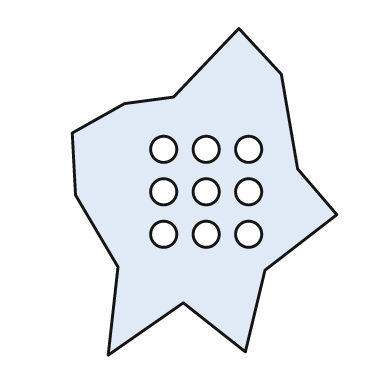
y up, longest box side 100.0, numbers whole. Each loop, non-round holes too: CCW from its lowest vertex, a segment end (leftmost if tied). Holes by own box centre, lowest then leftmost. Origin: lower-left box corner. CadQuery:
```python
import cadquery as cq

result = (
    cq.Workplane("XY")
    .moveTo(11.0, 0.0)
    .lineTo(34.0, 16.0)
    .lineTo(53.0, 1.0)
    .lineTo(59.0, 26.0)
    .lineTo(81.0, 43.0)
    .lineTo(69.0, 57.0)
    .lineTo(64.0, 86.0)
    .lineTo(51.0, 100.0)
    .lineTo(31.0, 79.0)
    .lineTo(16.0, 77.0)
    .lineTo(0.0, 68.0)
    .lineTo(1.0, 49.0)
    .lineTo(14.0, 27.0)
    .close()
    .moveTo(28.0, 37.0)
    .circle(4.0)
    .moveTo(41.0, 37.0)
    .circle(4.0)
    .moveTo(54.0, 37.0)
    .circle(4.0)
    .moveTo(28.0, 50.0)
    .circle(4.0)
    .moveTo(41.0, 50.0)
    .circle(4.0)
    .moveTo(54.0, 50.0)
    .circle(4.0)
    .moveTo(28.0, 63.0)
    .circle(4.0)
    .moveTo(41.0, 63.0)
    .circle(4.0)
    .moveTo(54.0, 63.0)
    .circle(4.0)
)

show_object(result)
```